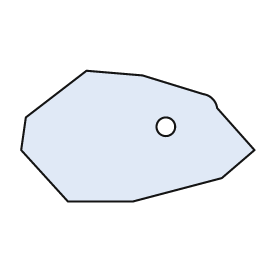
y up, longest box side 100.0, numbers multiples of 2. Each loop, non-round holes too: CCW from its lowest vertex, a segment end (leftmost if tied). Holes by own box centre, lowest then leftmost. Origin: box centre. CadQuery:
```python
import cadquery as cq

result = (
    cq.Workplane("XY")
    .moveTo(-30.0, -28.0)
    .lineTo(-2.0, -28.0)
    .lineTo(36.0, -18.0)
    .lineTo(50.0, -6.0)
    .lineTo(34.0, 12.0)
    .threePointArc((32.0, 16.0), (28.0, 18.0))
    .lineTo(2.0, 26.0)
    .lineTo(-22.0, 28.0)
    .lineTo(-48.0, 8.0)
    .lineTo(-50.0, -6.0)
    .close()
    .moveTo(12.0, 4.0)
    .circle(4.0)
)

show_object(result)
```